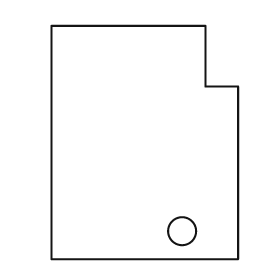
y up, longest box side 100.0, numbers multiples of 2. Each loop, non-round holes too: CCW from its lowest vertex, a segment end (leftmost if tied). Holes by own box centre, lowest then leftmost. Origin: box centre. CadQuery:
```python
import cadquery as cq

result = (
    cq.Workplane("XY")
    .moveTo(-40.0, -50.0)
    .lineTo(40.0, -50.0)
    .lineTo(40.0, 24.0)
    .lineTo(26.0, 24.0)
    .lineTo(26.0, 50.0)
    .lineTo(-40.0, 50.0)
    .close()
    .moveTo(16.0, -38.0)
    .circle(6.0)
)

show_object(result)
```